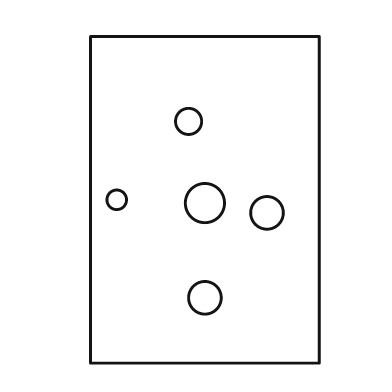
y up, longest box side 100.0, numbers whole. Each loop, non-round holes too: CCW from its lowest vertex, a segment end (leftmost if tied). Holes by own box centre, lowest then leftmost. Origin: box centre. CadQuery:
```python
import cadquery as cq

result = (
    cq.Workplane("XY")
    .moveTo(-35.0, -50.0)
    .lineTo(35.0, -50.0)
    .lineTo(35.0, 50.0)
    .lineTo(-35.0, 50.0)
    .close()
    .moveTo(0.0, -30.0)
    .circle(5.0)
    .moveTo(19.0, -4.0)
    .circle(5.0)
    .moveTo(0.0, -1.0)
    .circle(6.0)
    .moveTo(-27.0, 0.0)
    .circle(3.0)
    .moveTo(-5.0, 24.0)
    .circle(4.0)
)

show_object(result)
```